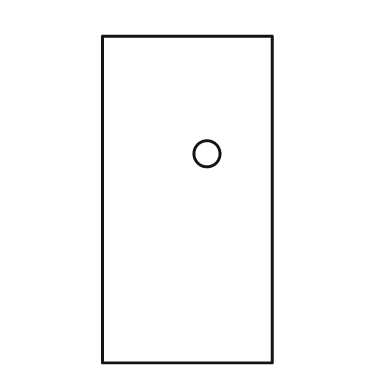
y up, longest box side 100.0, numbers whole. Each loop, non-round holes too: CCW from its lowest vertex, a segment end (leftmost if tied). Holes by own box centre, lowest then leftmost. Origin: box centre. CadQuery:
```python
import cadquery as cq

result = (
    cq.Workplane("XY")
    .moveTo(-26.0, -50.0)
    .lineTo(26.0, -50.0)
    .lineTo(26.0, 50.0)
    .lineTo(-26.0, 50.0)
    .close()
    .moveTo(6.0, 14.0)
    .circle(4.0)
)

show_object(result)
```